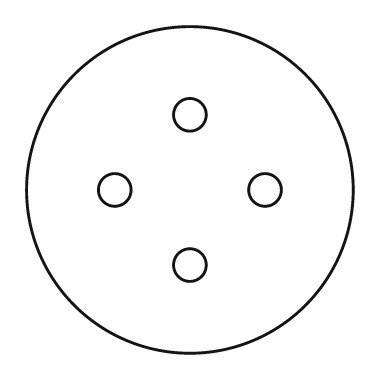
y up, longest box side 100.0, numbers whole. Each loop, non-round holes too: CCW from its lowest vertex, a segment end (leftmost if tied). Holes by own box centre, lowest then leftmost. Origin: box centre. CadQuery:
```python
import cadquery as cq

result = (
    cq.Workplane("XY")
    .moveTo(0.0, 0.0)
    .circle(50.0)
    .moveTo(0.0, -23.0)
    .circle(5.0)
    .moveTo(-23.0, 0.0)
    .circle(5.0)
    .moveTo(23.0, 0.0)
    .circle(5.0)
    .moveTo(0.0, 23.0)
    .circle(5.0)
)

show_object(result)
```